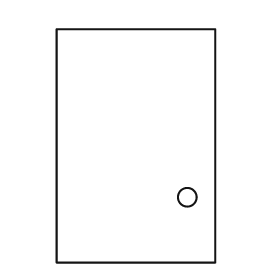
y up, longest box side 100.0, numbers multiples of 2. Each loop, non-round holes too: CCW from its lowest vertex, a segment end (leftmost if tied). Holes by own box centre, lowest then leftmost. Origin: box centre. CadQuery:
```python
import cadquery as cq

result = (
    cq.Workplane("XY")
    .moveTo(-34.0, -50.0)
    .lineTo(34.0, -50.0)
    .lineTo(34.0, 50.0)
    .lineTo(-34.0, 50.0)
    .close()
    .moveTo(22.0, -22.0)
    .circle(4.0)
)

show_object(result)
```